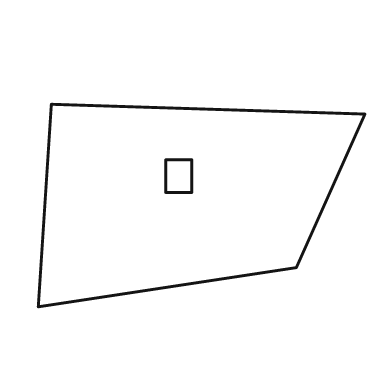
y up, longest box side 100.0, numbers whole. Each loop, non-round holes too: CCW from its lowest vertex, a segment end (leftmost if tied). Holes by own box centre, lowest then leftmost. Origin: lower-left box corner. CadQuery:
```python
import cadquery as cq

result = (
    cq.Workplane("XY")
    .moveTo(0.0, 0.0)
    .lineTo(79.0, 12.0)
    .lineTo(100.0, 59.0)
    .lineTo(4.0, 62.0)
    .close()
    .moveTo(39.0, 35.0)
    .lineTo(47.0, 35.0)
    .lineTo(47.0, 45.0)
    .lineTo(39.0, 45.0)
    .close()
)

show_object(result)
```